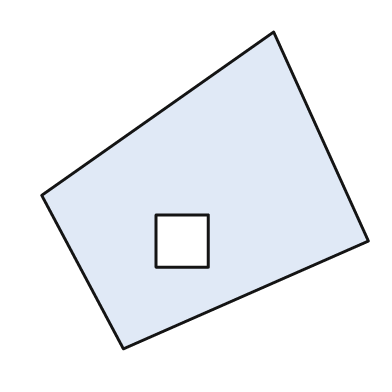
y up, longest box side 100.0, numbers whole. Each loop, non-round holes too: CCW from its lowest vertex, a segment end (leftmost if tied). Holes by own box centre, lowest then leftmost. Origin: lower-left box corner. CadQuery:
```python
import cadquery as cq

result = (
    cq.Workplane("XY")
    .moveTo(25.0, 0.0)
    .lineTo(100.0, 33.0)
    .lineTo(71.0, 97.0)
    .lineTo(0.0, 47.0)
    .close()
    .moveTo(35.0, 25.0)
    .lineTo(51.0, 25.0)
    .lineTo(51.0, 41.0)
    .lineTo(35.0, 41.0)
    .close()
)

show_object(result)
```